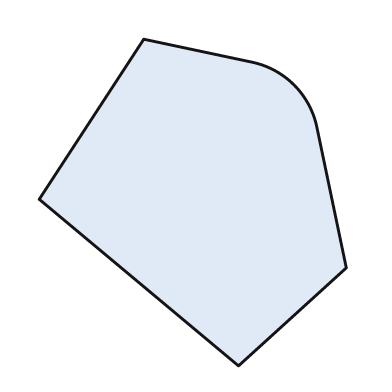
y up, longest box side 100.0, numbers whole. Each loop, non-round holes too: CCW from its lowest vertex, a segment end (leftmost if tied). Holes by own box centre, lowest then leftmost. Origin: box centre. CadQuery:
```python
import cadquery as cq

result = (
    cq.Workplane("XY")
    .moveTo(14.0, -50.0)
    .lineTo(47.0, -20.0)
    .lineTo(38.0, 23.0)
    .threePointArc((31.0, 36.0), (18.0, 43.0))
    .lineTo(-15.0, 50.0)
    .lineTo(-47.0, 1.0)
    .close()
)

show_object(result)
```